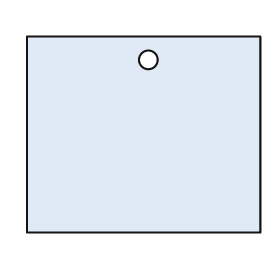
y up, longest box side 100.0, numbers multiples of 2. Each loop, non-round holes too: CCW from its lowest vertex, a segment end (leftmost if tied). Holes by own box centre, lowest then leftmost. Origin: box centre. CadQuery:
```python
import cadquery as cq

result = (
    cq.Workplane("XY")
    .moveTo(-50.0, -42.0)
    .lineTo(50.0, -42.0)
    .lineTo(50.0, 42.0)
    .lineTo(-50.0, 42.0)
    .close()
    .moveTo(2.0, 32.0)
    .circle(4.0)
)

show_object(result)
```